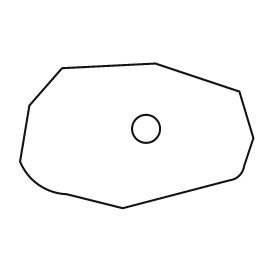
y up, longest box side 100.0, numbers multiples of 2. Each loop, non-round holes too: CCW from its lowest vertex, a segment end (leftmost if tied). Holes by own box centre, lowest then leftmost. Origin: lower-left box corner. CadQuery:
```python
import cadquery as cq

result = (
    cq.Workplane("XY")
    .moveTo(44.0, 0.0)
    .lineTo(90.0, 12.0)
    .threePointArc((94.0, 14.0), (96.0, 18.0))
    .lineTo(100.0, 30.0)
    .lineTo(94.0, 50.0)
    .lineTo(58.0, 62.0)
    .lineTo(18.0, 60.0)
    .lineTo(4.0, 44.0)
    .lineTo(0.0, 20.0)
    .threePointArc((8.0, 10.0), (20.0, 6.0))
    .close()
    .moveTo(54.0, 34.0)
    .circle(6.0)
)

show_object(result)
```